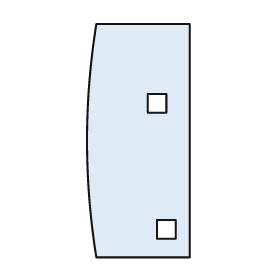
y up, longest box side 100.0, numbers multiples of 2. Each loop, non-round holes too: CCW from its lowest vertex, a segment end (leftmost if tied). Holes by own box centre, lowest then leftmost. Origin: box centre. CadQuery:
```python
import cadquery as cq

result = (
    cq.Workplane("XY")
    .moveTo(-18.0, -50.0)
    .lineTo(22.0, -50.0)
    .lineTo(22.0, 50.0)
    .lineTo(-18.0, 50.0)
    .threePointArc((-22.0, 0.0), (-18.0, -50.0))
    .close()
    .moveTo(8.0, -42.0)
    .lineTo(16.0, -42.0)
    .lineTo(16.0, -34.0)
    .lineTo(8.0, -34.0)
    .close()
    .moveTo(4.0, 12.0)
    .lineTo(12.0, 12.0)
    .lineTo(12.0, 20.0)
    .lineTo(4.0, 20.0)
    .close()
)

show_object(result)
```